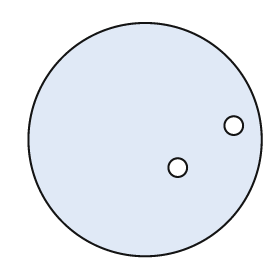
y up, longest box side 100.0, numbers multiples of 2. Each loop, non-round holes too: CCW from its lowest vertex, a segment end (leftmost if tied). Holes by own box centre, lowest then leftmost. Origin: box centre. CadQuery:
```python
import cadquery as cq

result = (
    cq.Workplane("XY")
    .moveTo(0.0, 0.0)
    .circle(50.0)
    .moveTo(14.0, -12.0)
    .circle(4.0)
    .moveTo(38.0, 6.0)
    .circle(4.0)
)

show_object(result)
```